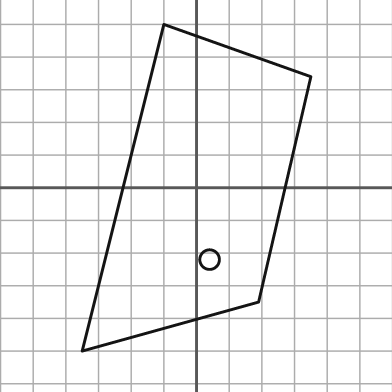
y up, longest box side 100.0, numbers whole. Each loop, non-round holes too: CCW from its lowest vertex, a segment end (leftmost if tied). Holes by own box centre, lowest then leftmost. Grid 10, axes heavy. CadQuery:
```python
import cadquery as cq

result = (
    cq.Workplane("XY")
    .moveTo(-35.0, -50.0)
    .lineTo(19.0, -35.0)
    .lineTo(35.0, 34.0)
    .lineTo(-10.0, 50.0)
    .close()
    .moveTo(4.0, -22.0)
    .circle(3.0)
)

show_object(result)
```